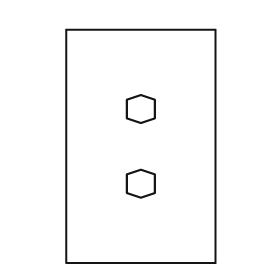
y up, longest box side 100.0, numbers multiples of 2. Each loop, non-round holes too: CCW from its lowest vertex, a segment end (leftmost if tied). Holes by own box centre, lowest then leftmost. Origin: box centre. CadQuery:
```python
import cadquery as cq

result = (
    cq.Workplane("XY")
    .moveTo(-32.0, -50.0)
    .lineTo(32.0, -50.0)
    .lineTo(32.0, 50.0)
    .lineTo(-32.0, 50.0)
    .close()
    .moveTo(0.0, -22.0)
    .lineTo(6.0, -20.0)
    .lineTo(6.0, -12.0)
    .lineTo(0.0, -10.0)
    .lineTo(-6.0, -12.0)
    .lineTo(-6.0, -20.0)
    .close()
    .moveTo(0.0, 10.0)
    .lineTo(6.0, 12.0)
    .lineTo(6.0, 20.0)
    .lineTo(0.0, 22.0)
    .lineTo(-6.0, 20.0)
    .lineTo(-6.0, 12.0)
    .close()
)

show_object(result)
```